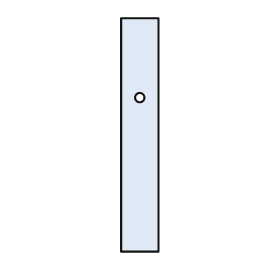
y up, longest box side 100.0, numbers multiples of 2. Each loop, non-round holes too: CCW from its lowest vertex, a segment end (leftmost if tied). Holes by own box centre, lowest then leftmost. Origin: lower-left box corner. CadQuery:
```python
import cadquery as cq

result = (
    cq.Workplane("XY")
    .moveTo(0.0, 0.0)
    .lineTo(16.0, 0.0)
    .lineTo(16.0, 100.0)
    .lineTo(0.0, 100.0)
    .close()
    .moveTo(8.0, 66.0)
    .circle(2.0)
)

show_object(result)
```